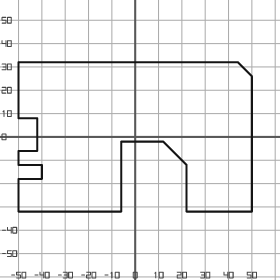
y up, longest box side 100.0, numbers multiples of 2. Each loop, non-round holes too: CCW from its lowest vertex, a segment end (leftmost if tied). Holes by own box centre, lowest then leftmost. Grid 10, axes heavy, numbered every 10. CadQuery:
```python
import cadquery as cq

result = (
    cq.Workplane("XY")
    .moveTo(-50.0, -32.0)
    .lineTo(-6.0, -32.0)
    .lineTo(-6.0, -2.0)
    .lineTo(12.0, -2.0)
    .lineTo(22.0, -12.0)
    .lineTo(22.0, -32.0)
    .lineTo(50.0, -32.0)
    .lineTo(50.0, 26.0)
    .lineTo(44.0, 32.0)
    .lineTo(-50.0, 32.0)
    .lineTo(-50.0, 8.0)
    .lineTo(-42.0, 8.0)
    .lineTo(-42.0, -6.0)
    .lineTo(-50.0, -6.0)
    .lineTo(-50.0, -12.0)
    .lineTo(-40.0, -12.0)
    .lineTo(-40.0, -18.0)
    .lineTo(-50.0, -18.0)
    .close()
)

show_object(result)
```